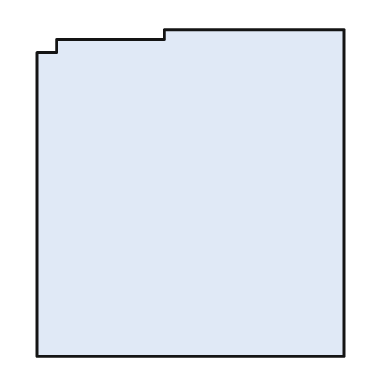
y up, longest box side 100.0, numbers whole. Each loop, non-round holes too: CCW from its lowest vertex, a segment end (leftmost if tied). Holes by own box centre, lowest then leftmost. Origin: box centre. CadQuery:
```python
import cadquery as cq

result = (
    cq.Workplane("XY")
    .moveTo(-47.0, -50.0)
    .lineTo(47.0, -50.0)
    .lineTo(47.0, 50.0)
    .lineTo(-8.0, 50.0)
    .lineTo(-8.0, 47.0)
    .lineTo(-41.0, 47.0)
    .lineTo(-41.0, 43.0)
    .lineTo(-47.0, 43.0)
    .close()
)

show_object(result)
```